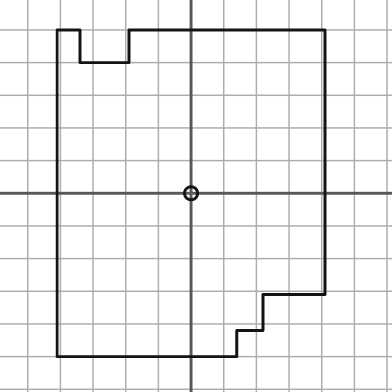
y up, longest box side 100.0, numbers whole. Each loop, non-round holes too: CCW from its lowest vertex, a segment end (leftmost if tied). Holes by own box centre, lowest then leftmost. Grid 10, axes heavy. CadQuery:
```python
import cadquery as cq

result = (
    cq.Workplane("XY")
    .moveTo(-41.0, -50.0)
    .lineTo(14.0, -50.0)
    .lineTo(14.0, -42.0)
    .lineTo(22.0, -42.0)
    .lineTo(22.0, -31.0)
    .lineTo(41.0, -31.0)
    .lineTo(41.0, 50.0)
    .lineTo(-19.0, 50.0)
    .lineTo(-19.0, 40.0)
    .lineTo(-34.0, 40.0)
    .lineTo(-34.0, 50.0)
    .lineTo(-41.0, 50.0)
    .close()
    .moveTo(0.0, 0.0)
    .circle(2.0)
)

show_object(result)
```